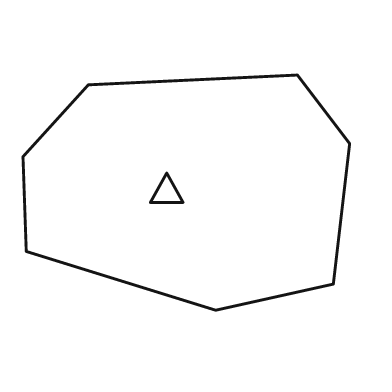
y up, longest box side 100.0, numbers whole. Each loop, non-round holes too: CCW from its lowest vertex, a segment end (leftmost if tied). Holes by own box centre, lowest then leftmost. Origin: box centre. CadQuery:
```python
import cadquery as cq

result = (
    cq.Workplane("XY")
    .moveTo(9.0, -36.0)
    .lineTo(45.0, -28.0)
    .lineTo(50.0, 15.0)
    .lineTo(34.0, 36.0)
    .lineTo(-30.0, 33.0)
    .lineTo(-50.0, 11.0)
    .lineTo(-49.0, -18.0)
    .close()
    .moveTo(-11.0, -3.0)
    .lineTo(-1.0, -3.0)
    .lineTo(-6.0, 6.0)
    .close()
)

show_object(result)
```